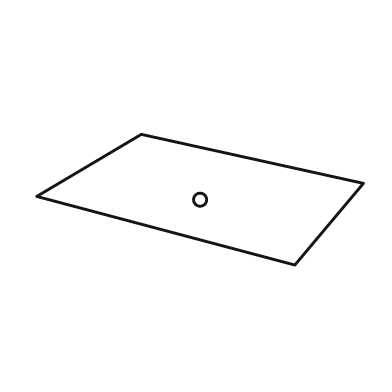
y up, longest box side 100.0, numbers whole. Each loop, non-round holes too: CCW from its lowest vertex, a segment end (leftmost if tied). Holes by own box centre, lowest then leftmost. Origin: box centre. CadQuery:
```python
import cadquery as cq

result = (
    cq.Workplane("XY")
    .moveTo(29.0, -20.0)
    .lineTo(50.0, 5.0)
    .lineTo(-18.0, 20.0)
    .lineTo(-50.0, 1.0)
    .close()
    .moveTo(0.0, 0.0)
    .circle(2.0)
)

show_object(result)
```